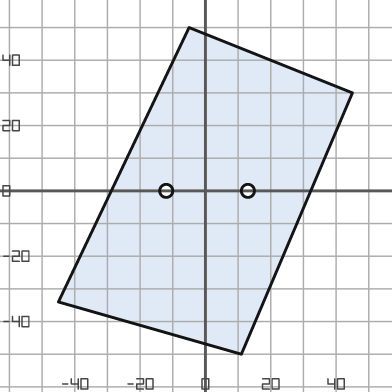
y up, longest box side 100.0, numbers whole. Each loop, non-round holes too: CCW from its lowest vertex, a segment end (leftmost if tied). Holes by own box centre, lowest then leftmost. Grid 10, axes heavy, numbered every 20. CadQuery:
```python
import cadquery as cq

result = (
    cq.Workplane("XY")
    .moveTo(11.0, -50.0)
    .lineTo(45.0, 30.0)
    .lineTo(-5.0, 50.0)
    .lineTo(-45.0, -34.0)
    .close()
    .moveTo(-12.0, 0.0)
    .circle(2.0)
    .moveTo(13.0, 0.0)
    .circle(2.0)
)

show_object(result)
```